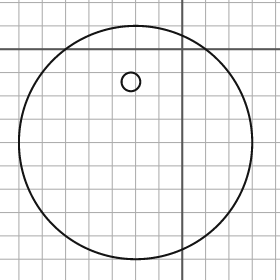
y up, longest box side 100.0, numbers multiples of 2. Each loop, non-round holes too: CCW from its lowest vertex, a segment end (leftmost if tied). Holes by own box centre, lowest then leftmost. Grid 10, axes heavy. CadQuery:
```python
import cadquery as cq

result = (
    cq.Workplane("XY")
    .moveTo(-20.0, -40.0)
    .circle(50.0)
    .moveTo(-22.0, -14.0)
    .circle(4.0)
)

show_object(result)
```